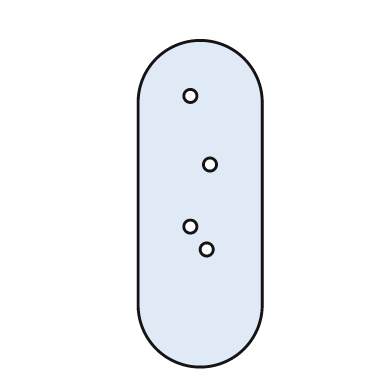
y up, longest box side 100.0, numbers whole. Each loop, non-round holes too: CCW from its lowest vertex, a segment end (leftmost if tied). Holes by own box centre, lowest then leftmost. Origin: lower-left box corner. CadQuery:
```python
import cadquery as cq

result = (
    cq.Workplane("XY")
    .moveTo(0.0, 19.0)
    .threePointArc((19.0, 0.0), (38.0, 19.0))
    .lineTo(38.0, 81.0)
    .threePointArc((19.0, 100.0), (0.0, 81.0))
    .close()
    .moveTo(21.0, 36.0)
    .circle(2.0)
    .moveTo(16.0, 43.0)
    .circle(2.0)
    .moveTo(22.0, 62.0)
    .circle(2.0)
    .moveTo(16.0, 83.0)
    .circle(2.0)
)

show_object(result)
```